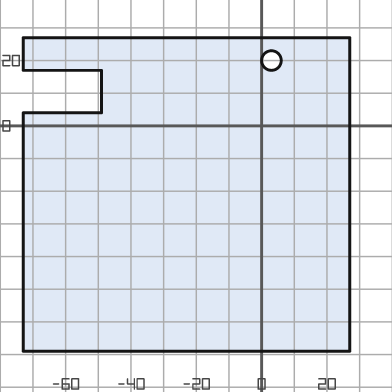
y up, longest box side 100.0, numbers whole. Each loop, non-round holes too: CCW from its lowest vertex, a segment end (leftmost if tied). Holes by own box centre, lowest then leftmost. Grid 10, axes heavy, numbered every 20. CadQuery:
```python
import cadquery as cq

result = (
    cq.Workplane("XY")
    .moveTo(-73.0, -69.0)
    .lineTo(27.0, -69.0)
    .lineTo(27.0, 27.0)
    .lineTo(-73.0, 27.0)
    .lineTo(-73.0, 17.0)
    .lineTo(-49.0, 17.0)
    .lineTo(-49.0, 4.0)
    .lineTo(-73.0, 4.0)
    .close()
    .moveTo(3.0, 20.0)
    .circle(3.0)
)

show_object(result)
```